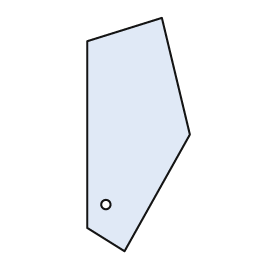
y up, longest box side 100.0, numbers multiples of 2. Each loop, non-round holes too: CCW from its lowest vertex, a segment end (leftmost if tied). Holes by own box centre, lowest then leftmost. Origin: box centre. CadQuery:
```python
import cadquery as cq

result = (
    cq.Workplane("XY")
    .moveTo(-6.0, -50.0)
    .lineTo(22.0, 0.0)
    .lineTo(10.0, 50.0)
    .lineTo(-22.0, 40.0)
    .lineTo(-22.0, -40.0)
    .close()
    .moveTo(-14.0, -30.0)
    .circle(2.0)
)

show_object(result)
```